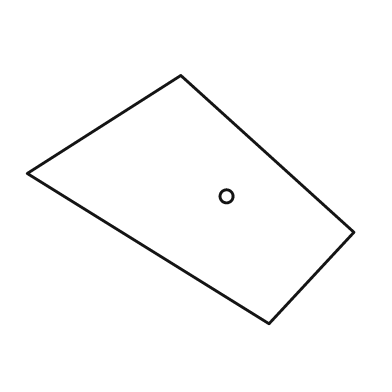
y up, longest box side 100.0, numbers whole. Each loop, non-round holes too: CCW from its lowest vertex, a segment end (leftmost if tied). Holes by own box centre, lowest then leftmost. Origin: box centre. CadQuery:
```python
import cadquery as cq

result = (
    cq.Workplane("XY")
    .moveTo(24.0, -38.0)
    .lineTo(50.0, -10.0)
    .lineTo(-3.0, 38.0)
    .lineTo(-50.0, 8.0)
    .close()
    .moveTo(11.0, 1.0)
    .circle(2.0)
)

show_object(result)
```